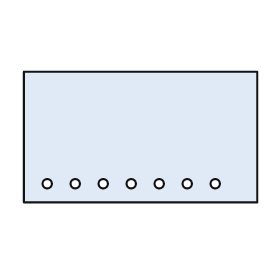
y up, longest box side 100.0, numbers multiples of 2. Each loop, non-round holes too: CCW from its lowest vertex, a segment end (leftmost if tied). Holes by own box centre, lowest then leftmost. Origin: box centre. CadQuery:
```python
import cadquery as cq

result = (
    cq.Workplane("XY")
    .moveTo(-50.0, -28.0)
    .lineTo(50.0, -28.0)
    .lineTo(50.0, 28.0)
    .lineTo(-50.0, 28.0)
    .close()
    .moveTo(-40.0, -20.0)
    .circle(2.0)
    .moveTo(-28.0, -20.0)
    .circle(2.0)
    .moveTo(-16.0, -20.0)
    .circle(2.0)
    .moveTo(-4.0, -20.0)
    .circle(2.0)
    .moveTo(8.0, -20.0)
    .circle(2.0)
    .moveTo(20.0, -20.0)
    .circle(2.0)
    .moveTo(32.0, -20.0)
    .circle(2.0)
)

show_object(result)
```